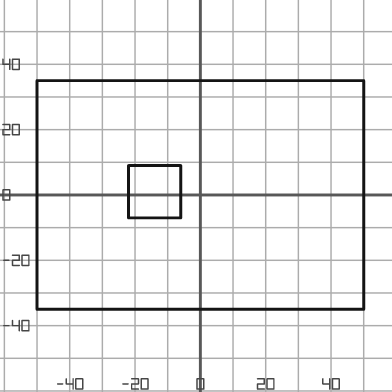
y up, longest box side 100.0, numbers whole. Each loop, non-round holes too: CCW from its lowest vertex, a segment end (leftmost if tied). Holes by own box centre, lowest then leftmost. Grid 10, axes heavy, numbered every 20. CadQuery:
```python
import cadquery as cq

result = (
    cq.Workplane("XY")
    .moveTo(-50.0, -35.0)
    .lineTo(50.0, -35.0)
    .lineTo(50.0, 35.0)
    .lineTo(-50.0, 35.0)
    .close()
    .moveTo(-22.0, -7.0)
    .lineTo(-6.0, -7.0)
    .lineTo(-6.0, 9.0)
    .lineTo(-22.0, 9.0)
    .close()
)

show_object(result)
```